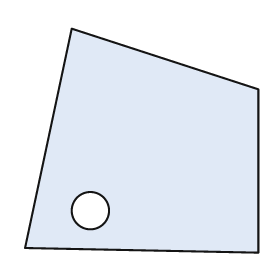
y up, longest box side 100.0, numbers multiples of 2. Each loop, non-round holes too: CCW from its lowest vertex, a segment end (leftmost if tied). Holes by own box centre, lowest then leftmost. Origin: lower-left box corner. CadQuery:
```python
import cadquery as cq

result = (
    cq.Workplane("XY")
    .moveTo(100.0, 0.0)
    .lineTo(100.0, 70.0)
    .lineTo(20.0, 96.0)
    .lineTo(0.0, 2.0)
    .close()
    .moveTo(28.0, 18.0)
    .circle(8.0)
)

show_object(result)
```